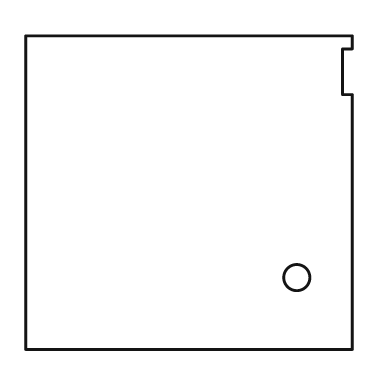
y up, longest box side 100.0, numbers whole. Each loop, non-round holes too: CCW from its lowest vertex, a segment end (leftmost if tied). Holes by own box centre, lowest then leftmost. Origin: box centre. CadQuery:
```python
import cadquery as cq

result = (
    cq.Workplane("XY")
    .moveTo(-50.0, -48.0)
    .lineTo(50.0, -48.0)
    .lineTo(50.0, 30.0)
    .lineTo(47.0, 30.0)
    .lineTo(47.0, 44.0)
    .lineTo(50.0, 44.0)
    .lineTo(50.0, 48.0)
    .lineTo(-50.0, 48.0)
    .close()
    .moveTo(33.0, -26.0)
    .circle(4.0)
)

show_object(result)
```